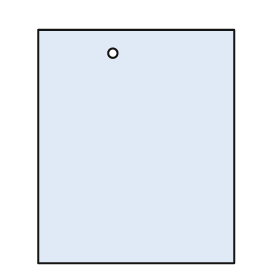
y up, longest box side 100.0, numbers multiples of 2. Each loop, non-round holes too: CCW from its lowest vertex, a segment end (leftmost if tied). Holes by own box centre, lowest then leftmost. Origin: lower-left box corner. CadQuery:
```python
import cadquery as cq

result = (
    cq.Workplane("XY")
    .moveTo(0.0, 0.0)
    .lineTo(84.0, 0.0)
    .lineTo(84.0, 100.0)
    .lineTo(0.0, 100.0)
    .close()
    .moveTo(32.0, 90.0)
    .circle(2.0)
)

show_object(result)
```